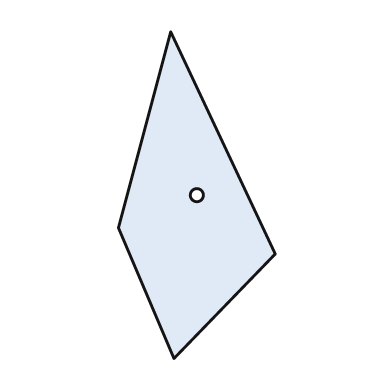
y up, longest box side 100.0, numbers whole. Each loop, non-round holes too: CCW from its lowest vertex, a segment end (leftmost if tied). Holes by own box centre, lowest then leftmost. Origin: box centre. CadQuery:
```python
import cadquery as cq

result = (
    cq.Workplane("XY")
    .moveTo(-7.0, -50.0)
    .lineTo(24.0, -18.0)
    .lineTo(-8.0, 50.0)
    .lineTo(-24.0, -10.0)
    .close()
    .moveTo(0.0, 0.0)
    .circle(2.0)
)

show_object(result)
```